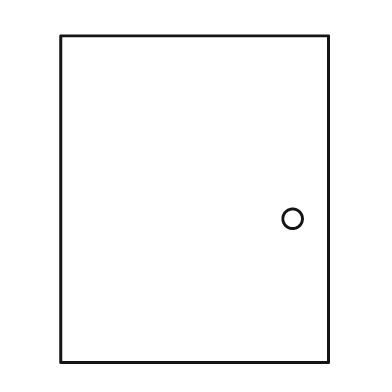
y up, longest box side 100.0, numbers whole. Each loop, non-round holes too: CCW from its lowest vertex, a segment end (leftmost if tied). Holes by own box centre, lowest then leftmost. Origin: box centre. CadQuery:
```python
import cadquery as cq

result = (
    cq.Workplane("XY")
    .moveTo(-41.0, -50.0)
    .lineTo(41.0, -50.0)
    .lineTo(41.0, 50.0)
    .lineTo(-41.0, 50.0)
    .close()
    .moveTo(30.0, -6.0)
    .circle(3.0)
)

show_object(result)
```